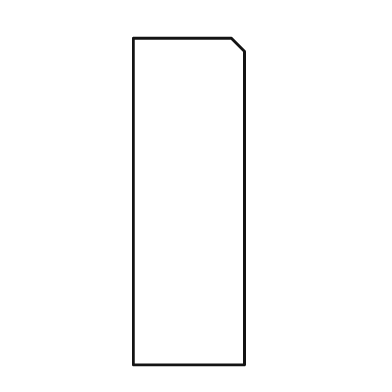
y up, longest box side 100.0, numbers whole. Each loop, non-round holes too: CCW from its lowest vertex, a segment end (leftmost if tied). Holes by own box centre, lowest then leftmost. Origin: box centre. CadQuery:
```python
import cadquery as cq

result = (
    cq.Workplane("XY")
    .moveTo(-17.0, -50.0)
    .lineTo(17.0, -50.0)
    .lineTo(17.0, 46.0)
    .lineTo(13.0, 50.0)
    .lineTo(-17.0, 50.0)
    .close()
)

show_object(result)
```